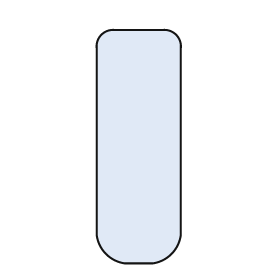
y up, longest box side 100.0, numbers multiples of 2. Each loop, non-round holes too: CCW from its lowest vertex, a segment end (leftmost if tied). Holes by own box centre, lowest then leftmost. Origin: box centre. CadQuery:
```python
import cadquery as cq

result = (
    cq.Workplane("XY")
    .moveTo(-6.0, -50.0)
    .lineTo(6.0, -50.0)
    .threePointArc((14.0, -46.0), (18.0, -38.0))
    .lineTo(18.0, 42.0)
    .threePointArc((16.0, 48.0), (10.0, 50.0))
    .lineTo(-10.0, 50.0)
    .threePointArc((-16.0, 48.0), (-18.0, 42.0))
    .lineTo(-18.0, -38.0)
    .threePointArc((-14.0, -46.0), (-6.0, -50.0))
    .close()
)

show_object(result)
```